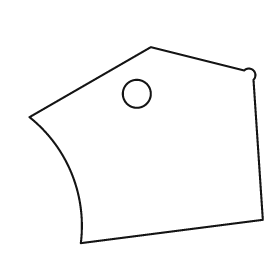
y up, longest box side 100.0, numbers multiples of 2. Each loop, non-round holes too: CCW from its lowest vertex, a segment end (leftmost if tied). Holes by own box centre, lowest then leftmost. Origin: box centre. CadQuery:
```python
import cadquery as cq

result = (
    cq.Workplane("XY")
    .moveTo(-28.0, -42.0)
    .lineTo(50.0, -32.0)
    .lineTo(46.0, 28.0)
    .threePointArc((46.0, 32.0), (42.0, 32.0))
    .lineTo(2.0, 42.0)
    .lineTo(-50.0, 12.0)
    .threePointArc((-32.0, -12.0), (-28.0, -42.0))
    .close()
    .moveTo(-4.0, 22.0)
    .circle(6.0)
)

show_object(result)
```